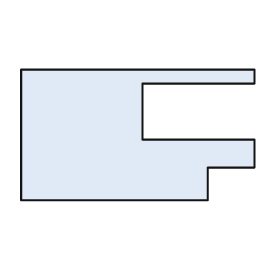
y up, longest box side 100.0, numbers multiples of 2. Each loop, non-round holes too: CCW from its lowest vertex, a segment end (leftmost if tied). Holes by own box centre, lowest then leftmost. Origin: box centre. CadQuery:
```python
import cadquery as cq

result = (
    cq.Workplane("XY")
    .moveTo(-50.0, -28.0)
    .lineTo(30.0, -28.0)
    .lineTo(30.0, -14.0)
    .lineTo(50.0, -14.0)
    .lineTo(50.0, -2.0)
    .lineTo(2.0, -2.0)
    .lineTo(2.0, 22.0)
    .lineTo(50.0, 22.0)
    .lineTo(50.0, 28.0)
    .lineTo(-50.0, 28.0)
    .close()
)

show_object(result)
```